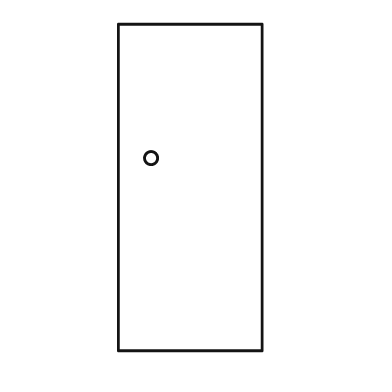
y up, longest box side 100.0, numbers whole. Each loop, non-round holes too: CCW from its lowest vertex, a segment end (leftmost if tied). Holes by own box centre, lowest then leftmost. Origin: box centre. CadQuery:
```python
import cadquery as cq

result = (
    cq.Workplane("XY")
    .moveTo(-22.0, -50.0)
    .lineTo(22.0, -50.0)
    .lineTo(22.0, 50.0)
    .lineTo(-22.0, 50.0)
    .close()
    .moveTo(-12.0, 9.0)
    .circle(2.0)
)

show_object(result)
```